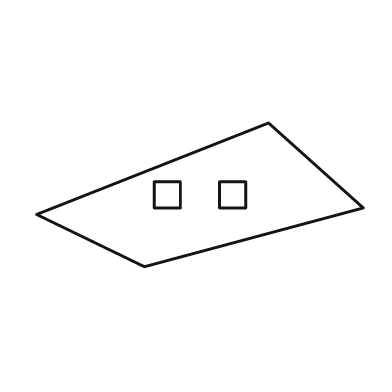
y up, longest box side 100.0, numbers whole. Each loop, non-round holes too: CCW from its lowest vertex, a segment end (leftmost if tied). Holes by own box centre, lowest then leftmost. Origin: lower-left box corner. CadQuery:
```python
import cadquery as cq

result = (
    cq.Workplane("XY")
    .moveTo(33.0, 0.0)
    .lineTo(100.0, 18.0)
    .lineTo(71.0, 44.0)
    .lineTo(0.0, 16.0)
    .close()
    .moveTo(36.0, 18.0)
    .lineTo(44.0, 18.0)
    .lineTo(44.0, 26.0)
    .lineTo(36.0, 26.0)
    .close()
    .moveTo(56.0, 18.0)
    .lineTo(64.0, 18.0)
    .lineTo(64.0, 26.0)
    .lineTo(56.0, 26.0)
    .close()
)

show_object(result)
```